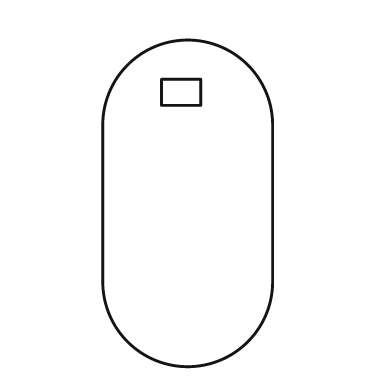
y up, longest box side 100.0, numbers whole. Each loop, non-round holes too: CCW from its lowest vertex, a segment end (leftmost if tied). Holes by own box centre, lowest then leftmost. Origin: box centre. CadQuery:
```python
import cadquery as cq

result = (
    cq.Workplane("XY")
    .moveTo(-26.0, -24.0)
    .threePointArc((0.0, -50.0), (26.0, -24.0))
    .lineTo(26.0, 24.0)
    .threePointArc((0.0, 50.0), (-26.0, 24.0))
    .close()
    .moveTo(-8.0, 30.0)
    .lineTo(4.0, 30.0)
    .lineTo(4.0, 38.0)
    .lineTo(-8.0, 38.0)
    .close()
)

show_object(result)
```